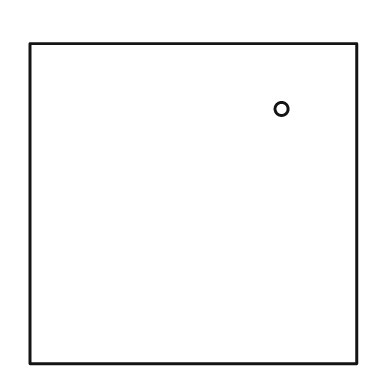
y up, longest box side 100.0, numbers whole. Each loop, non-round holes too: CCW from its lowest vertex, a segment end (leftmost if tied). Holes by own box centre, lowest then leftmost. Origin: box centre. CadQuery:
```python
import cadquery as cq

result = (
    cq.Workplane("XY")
    .moveTo(-50.0, -49.0)
    .lineTo(50.0, -49.0)
    .lineTo(50.0, 49.0)
    .lineTo(-50.0, 49.0)
    .close()
    .moveTo(27.0, 29.0)
    .circle(2.0)
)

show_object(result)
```